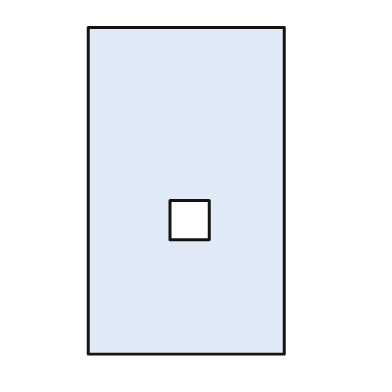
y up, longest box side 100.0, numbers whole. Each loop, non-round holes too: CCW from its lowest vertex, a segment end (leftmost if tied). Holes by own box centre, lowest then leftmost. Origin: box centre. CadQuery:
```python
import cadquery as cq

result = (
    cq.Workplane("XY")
    .moveTo(-30.0, -50.0)
    .lineTo(30.0, -50.0)
    .lineTo(30.0, 50.0)
    .lineTo(-30.0, 50.0)
    .close()
    .moveTo(-5.0, -15.0)
    .lineTo(7.0, -15.0)
    .lineTo(7.0, -3.0)
    .lineTo(-5.0, -3.0)
    .close()
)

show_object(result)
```